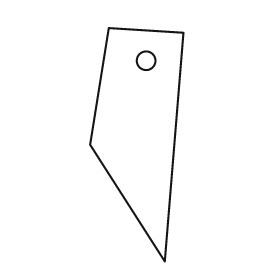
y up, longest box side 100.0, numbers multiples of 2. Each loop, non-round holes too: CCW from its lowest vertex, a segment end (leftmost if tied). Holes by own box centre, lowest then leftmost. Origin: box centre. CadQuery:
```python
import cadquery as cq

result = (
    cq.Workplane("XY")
    .moveTo(12.0, -50.0)
    .lineTo(20.0, 48.0)
    .lineTo(-12.0, 50.0)
    .lineTo(-20.0, 0.0)
    .close()
    .moveTo(4.0, 36.0)
    .circle(4.0)
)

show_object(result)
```